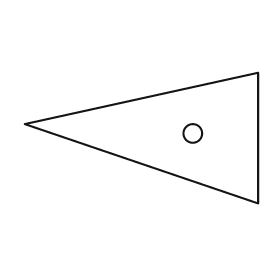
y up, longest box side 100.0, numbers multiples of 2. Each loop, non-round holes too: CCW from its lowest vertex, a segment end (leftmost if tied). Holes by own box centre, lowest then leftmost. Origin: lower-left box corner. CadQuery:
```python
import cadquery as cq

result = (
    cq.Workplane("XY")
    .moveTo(100.0, 0.0)
    .lineTo(100.0, 56.0)
    .lineTo(0.0, 34.0)
    .close()
    .moveTo(72.0, 30.0)
    .circle(4.0)
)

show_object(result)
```